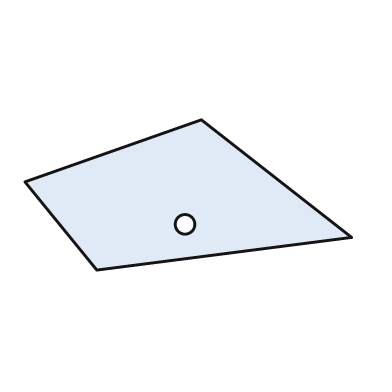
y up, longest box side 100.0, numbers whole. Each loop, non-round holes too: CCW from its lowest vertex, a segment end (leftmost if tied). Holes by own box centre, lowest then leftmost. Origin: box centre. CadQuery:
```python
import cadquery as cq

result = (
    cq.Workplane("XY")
    .moveTo(-28.0, -23.0)
    .lineTo(50.0, -13.0)
    .lineTo(4.0, 23.0)
    .lineTo(-50.0, 4.0)
    .close()
    .moveTo(-1.0, -9.0)
    .circle(3.0)
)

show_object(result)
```